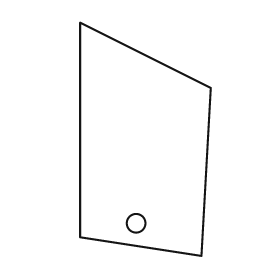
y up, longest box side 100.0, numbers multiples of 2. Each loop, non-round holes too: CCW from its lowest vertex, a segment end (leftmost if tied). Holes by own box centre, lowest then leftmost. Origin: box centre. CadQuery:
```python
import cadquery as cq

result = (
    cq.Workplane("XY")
    .moveTo(24.0, -50.0)
    .lineTo(28.0, 22.0)
    .lineTo(-28.0, 50.0)
    .lineTo(-28.0, -42.0)
    .close()
    .moveTo(-4.0, -36.0)
    .circle(4.0)
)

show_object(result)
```